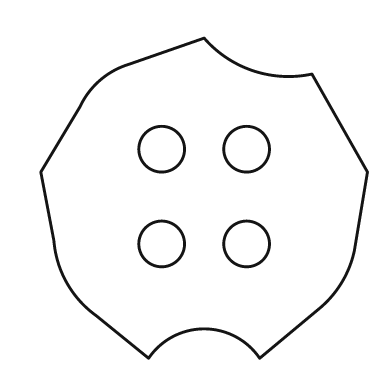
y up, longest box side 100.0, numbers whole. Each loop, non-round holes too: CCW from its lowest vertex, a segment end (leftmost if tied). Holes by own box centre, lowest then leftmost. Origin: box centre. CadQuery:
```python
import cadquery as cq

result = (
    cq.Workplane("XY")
    .moveTo(-17.0, -49.0)
    .threePointArc((0.0, -40.0), (17.0, -49.0))
    .lineTo(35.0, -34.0)
    .threePointArc((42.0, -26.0), (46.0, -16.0))
    .lineTo(50.0, 8.0)
    .lineTo(33.0, 38.0)
    .threePointArc((15.0, 39.0), (0.0, 49.0))
    .lineTo(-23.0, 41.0)
    .threePointArc((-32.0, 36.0), (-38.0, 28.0))
    .lineTo(-50.0, 8.0)
    .lineTo(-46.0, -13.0)
    .threePointArc((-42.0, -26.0), (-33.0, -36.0))
    .close()
    .moveTo(-13.0, -14.0)
    .circle(7.0)
    .moveTo(13.0, -14.0)
    .circle(7.0)
    .moveTo(-13.0, 15.0)
    .circle(7.0)
    .moveTo(13.0, 15.0)
    .circle(7.0)
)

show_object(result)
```